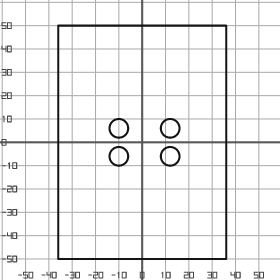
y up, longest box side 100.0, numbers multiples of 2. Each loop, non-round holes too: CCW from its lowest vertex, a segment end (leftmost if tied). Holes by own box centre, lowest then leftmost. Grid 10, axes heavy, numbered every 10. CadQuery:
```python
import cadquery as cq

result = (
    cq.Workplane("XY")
    .moveTo(-36.0, -50.0)
    .lineTo(36.0, -50.0)
    .lineTo(36.0, 50.0)
    .lineTo(-36.0, 50.0)
    .close()
    .moveTo(-10.0, -6.0)
    .circle(4.0)
    .moveTo(12.0, -6.0)
    .circle(4.0)
    .moveTo(-10.0, 6.0)
    .circle(4.0)
    .moveTo(12.0, 6.0)
    .circle(4.0)
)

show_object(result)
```